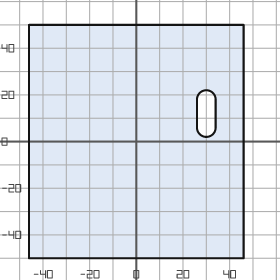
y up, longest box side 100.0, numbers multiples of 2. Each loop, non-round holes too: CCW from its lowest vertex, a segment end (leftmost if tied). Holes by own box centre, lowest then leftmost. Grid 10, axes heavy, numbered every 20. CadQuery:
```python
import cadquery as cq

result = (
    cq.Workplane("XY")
    .moveTo(-46.0, -50.0)
    .lineTo(46.0, -50.0)
    .lineTo(46.0, 50.0)
    .lineTo(-46.0, 50.0)
    .close()
    .moveTo(26.0, 6.0)
    .threePointArc((30.0, 2.0), (34.0, 6.0))
    .lineTo(34.0, 18.0)
    .threePointArc((30.0, 22.0), (26.0, 18.0))
    .close()
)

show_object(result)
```